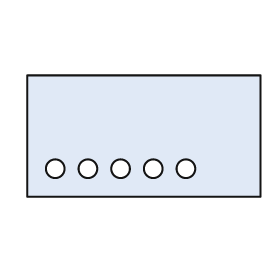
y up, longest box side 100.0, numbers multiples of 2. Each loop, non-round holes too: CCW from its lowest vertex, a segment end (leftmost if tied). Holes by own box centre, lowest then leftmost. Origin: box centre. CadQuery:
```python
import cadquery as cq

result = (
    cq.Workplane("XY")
    .moveTo(-50.0, -26.0)
    .lineTo(50.0, -26.0)
    .lineTo(50.0, 26.0)
    .lineTo(-50.0, 26.0)
    .close()
    .moveTo(-38.0, -14.0)
    .circle(4.0)
    .moveTo(-24.0, -14.0)
    .circle(4.0)
    .moveTo(-10.0, -14.0)
    .circle(4.0)
    .moveTo(4.0, -14.0)
    .circle(4.0)
    .moveTo(18.0, -14.0)
    .circle(4.0)
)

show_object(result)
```